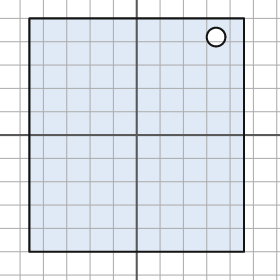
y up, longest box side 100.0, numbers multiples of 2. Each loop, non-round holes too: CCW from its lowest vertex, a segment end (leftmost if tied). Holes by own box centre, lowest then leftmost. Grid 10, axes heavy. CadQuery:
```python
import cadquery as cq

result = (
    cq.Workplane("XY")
    .moveTo(-46.0, -50.0)
    .lineTo(46.0, -50.0)
    .lineTo(46.0, 50.0)
    .lineTo(-46.0, 50.0)
    .close()
    .moveTo(34.0, 42.0)
    .circle(4.0)
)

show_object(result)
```